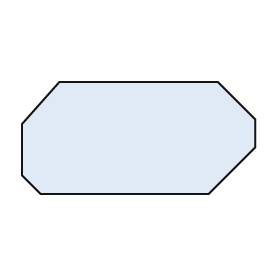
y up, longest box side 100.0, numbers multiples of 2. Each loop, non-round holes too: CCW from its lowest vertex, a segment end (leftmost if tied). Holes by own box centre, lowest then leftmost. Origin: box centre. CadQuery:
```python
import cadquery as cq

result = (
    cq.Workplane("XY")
    .moveTo(-42.0, -24.0)
    .lineTo(30.0, -24.0)
    .lineTo(50.0, -4.0)
    .lineTo(50.0, 8.0)
    .lineTo(34.0, 24.0)
    .lineTo(-34.0, 24.0)
    .lineTo(-50.0, 6.0)
    .lineTo(-50.0, -16.0)
    .close()
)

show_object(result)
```